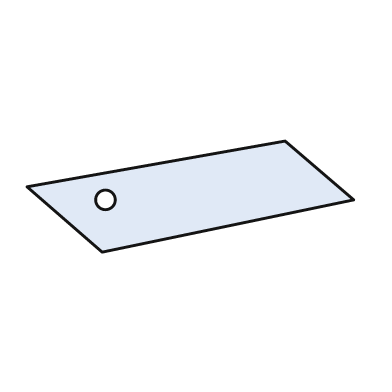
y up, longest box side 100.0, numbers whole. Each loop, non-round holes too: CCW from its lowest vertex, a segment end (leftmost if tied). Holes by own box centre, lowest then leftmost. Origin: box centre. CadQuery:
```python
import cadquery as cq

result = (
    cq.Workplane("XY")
    .moveTo(-27.0, -17.0)
    .lineTo(50.0, -1.0)
    .lineTo(29.0, 17.0)
    .lineTo(-50.0, 3.0)
    .close()
    .moveTo(-26.0, -1.0)
    .circle(3.0)
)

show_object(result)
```